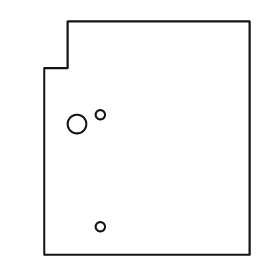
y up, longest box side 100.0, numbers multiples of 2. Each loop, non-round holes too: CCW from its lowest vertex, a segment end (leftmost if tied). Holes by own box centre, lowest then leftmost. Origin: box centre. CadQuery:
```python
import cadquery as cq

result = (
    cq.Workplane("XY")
    .moveTo(-44.0, -50.0)
    .lineTo(44.0, -50.0)
    .lineTo(44.0, 50.0)
    .lineTo(-34.0, 50.0)
    .lineTo(-34.0, 30.0)
    .lineTo(-44.0, 30.0)
    .close()
    .moveTo(-20.0, -38.0)
    .circle(2.0)
    .moveTo(-30.0, 6.0)
    .circle(4.0)
    .moveTo(-20.0, 10.0)
    .circle(2.0)
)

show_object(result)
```